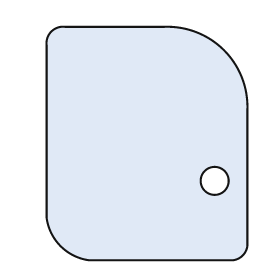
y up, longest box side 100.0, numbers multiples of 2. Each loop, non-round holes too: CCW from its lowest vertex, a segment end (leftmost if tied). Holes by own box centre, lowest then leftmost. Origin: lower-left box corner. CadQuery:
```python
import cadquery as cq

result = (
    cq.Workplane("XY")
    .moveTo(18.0, 0.0)
    .lineTo(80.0, 0.0)
    .threePointArc((84.0, 2.0), (86.0, 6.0))
    .lineTo(86.0, 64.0)
    .threePointArc((76.0, 90.0), (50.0, 100.0))
    .lineTo(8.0, 100.0)
    .threePointArc((2.0, 98.0), (0.0, 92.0))
    .lineTo(0.0, 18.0)
    .threePointArc((6.0, 6.0), (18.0, 0.0))
    .close()
    .moveTo(72.0, 34.0)
    .circle(6.0)
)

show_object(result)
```